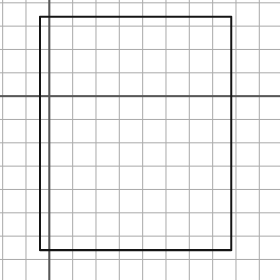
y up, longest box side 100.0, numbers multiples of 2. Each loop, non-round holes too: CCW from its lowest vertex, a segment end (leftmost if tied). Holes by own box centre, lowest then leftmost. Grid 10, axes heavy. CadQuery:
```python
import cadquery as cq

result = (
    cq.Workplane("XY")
    .moveTo(-4.0, -66.0)
    .lineTo(78.0, -66.0)
    .lineTo(78.0, 34.0)
    .lineTo(-4.0, 34.0)
    .close()
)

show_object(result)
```